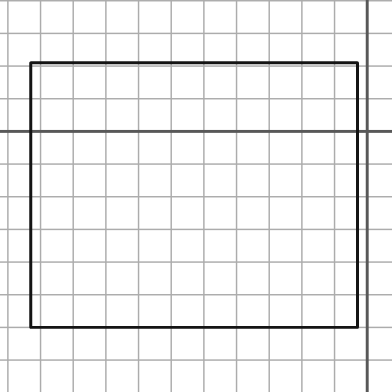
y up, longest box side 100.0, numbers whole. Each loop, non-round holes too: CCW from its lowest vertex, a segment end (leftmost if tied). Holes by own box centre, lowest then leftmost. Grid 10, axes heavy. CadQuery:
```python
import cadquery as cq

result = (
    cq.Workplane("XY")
    .moveTo(-103.0, -60.0)
    .lineTo(-3.0, -60.0)
    .lineTo(-3.0, 21.0)
    .lineTo(-103.0, 21.0)
    .close()
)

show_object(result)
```